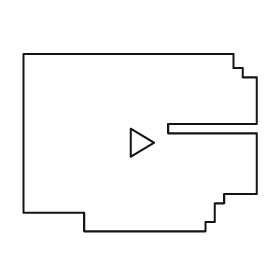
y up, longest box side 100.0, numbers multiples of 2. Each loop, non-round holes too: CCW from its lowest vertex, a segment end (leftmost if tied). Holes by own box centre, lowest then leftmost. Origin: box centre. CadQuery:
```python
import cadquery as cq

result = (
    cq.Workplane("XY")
    .moveTo(-24.0, -38.0)
    .lineTo(28.0, -38.0)
    .lineTo(28.0, -34.0)
    .lineTo(32.0, -34.0)
    .lineTo(32.0, -26.0)
    .lineTo(36.0, -26.0)
    .lineTo(36.0, -22.0)
    .lineTo(50.0, -22.0)
    .lineTo(50.0, 4.0)
    .lineTo(12.0, 4.0)
    .lineTo(12.0, 8.0)
    .lineTo(50.0, 8.0)
    .lineTo(50.0, 28.0)
    .lineTo(44.0, 28.0)
    .lineTo(44.0, 32.0)
    .lineTo(40.0, 32.0)
    .lineTo(40.0, 38.0)
    .lineTo(-50.0, 38.0)
    .lineTo(-50.0, -30.0)
    .lineTo(-24.0, -30.0)
    .close()
    .moveTo(-4.0, -6.0)
    .lineTo(6.0, 0.0)
    .lineTo(-4.0, 6.0)
    .close()
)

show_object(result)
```